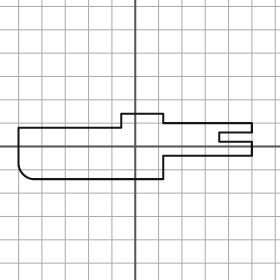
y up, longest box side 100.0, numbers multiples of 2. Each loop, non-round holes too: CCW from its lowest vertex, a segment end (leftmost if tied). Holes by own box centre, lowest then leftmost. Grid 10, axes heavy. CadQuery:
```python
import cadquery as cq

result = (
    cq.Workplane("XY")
    .moveTo(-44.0, -14.0)
    .lineTo(12.0, -14.0)
    .lineTo(12.0, -4.0)
    .lineTo(50.0, -4.0)
    .lineTo(50.0, 2.0)
    .lineTo(36.0, 2.0)
    .lineTo(36.0, 6.0)
    .lineTo(50.0, 6.0)
    .lineTo(50.0, 10.0)
    .lineTo(12.0, 10.0)
    .lineTo(12.0, 14.0)
    .lineTo(-6.0, 14.0)
    .lineTo(-6.0, 8.0)
    .lineTo(-50.0, 8.0)
    .lineTo(-50.0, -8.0)
    .threePointArc((-48.0, -12.0), (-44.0, -14.0))
    .close()
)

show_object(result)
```